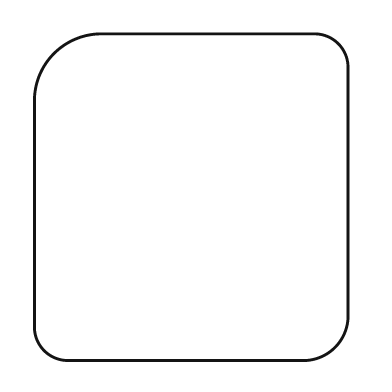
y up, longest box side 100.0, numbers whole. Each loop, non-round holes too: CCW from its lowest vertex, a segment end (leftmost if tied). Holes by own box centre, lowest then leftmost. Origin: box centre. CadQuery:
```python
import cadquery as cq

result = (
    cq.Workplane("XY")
    .moveTo(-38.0, -50.0)
    .lineTo(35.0, -50.0)
    .threePointArc((44.0, -46.0), (48.0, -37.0))
    .lineTo(48.0, 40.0)
    .threePointArc((45.0, 47.0), (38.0, 50.0))
    .lineTo(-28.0, 50.0)
    .threePointArc((-42.0, 44.0), (-48.0, 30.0))
    .lineTo(-48.0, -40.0)
    .threePointArc((-45.0, -47.0), (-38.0, -50.0))
    .close()
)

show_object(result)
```